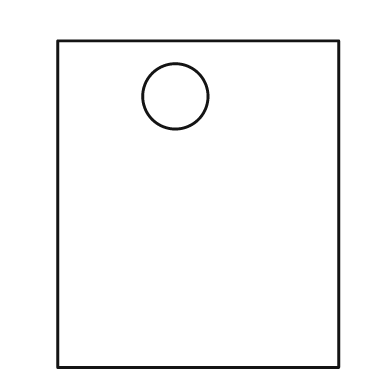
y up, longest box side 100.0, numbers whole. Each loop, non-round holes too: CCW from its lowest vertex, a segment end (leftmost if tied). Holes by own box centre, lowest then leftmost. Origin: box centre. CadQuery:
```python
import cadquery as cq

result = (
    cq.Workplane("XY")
    .moveTo(-43.0, -50.0)
    .lineTo(43.0, -50.0)
    .lineTo(43.0, 50.0)
    .lineTo(-43.0, 50.0)
    .close()
    .moveTo(-7.0, 33.0)
    .circle(10.0)
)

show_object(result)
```